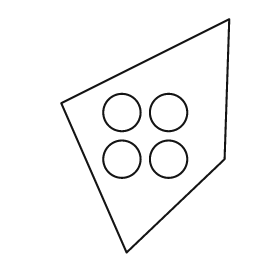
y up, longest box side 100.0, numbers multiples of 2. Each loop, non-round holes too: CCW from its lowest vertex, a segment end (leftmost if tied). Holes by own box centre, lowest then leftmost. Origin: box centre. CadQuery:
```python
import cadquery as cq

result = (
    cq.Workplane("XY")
    .moveTo(-8.0, -50.0)
    .lineTo(34.0, -10.0)
    .lineTo(36.0, 50.0)
    .lineTo(-36.0, 14.0)
    .close()
    .moveTo(-10.0, -10.0)
    .circle(8.0)
    .moveTo(10.0, -10.0)
    .circle(8.0)
    .moveTo(-10.0, 10.0)
    .circle(8.0)
    .moveTo(10.0, 10.0)
    .circle(8.0)
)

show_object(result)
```